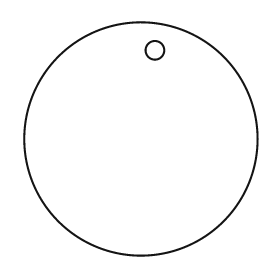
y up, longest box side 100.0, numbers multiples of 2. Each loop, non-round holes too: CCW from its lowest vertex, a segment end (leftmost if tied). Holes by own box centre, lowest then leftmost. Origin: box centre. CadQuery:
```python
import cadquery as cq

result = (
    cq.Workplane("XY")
    .moveTo(0.0, 0.0)
    .circle(50.0)
    .moveTo(6.0, 38.0)
    .circle(4.0)
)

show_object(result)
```